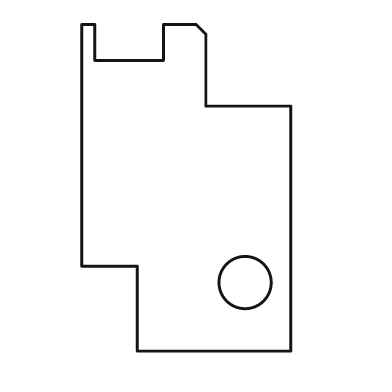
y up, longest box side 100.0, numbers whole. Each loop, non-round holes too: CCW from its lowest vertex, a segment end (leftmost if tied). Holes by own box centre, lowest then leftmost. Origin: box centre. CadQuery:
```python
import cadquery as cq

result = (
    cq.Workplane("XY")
    .moveTo(-15.0, -50.0)
    .lineTo(32.0, -50.0)
    .lineTo(32.0, 25.0)
    .lineTo(6.0, 25.0)
    .lineTo(6.0, 47.0)
    .lineTo(3.0, 50.0)
    .lineTo(-7.0, 50.0)
    .lineTo(-7.0, 39.0)
    .lineTo(-28.0, 39.0)
    .lineTo(-28.0, 50.0)
    .lineTo(-32.0, 50.0)
    .lineTo(-32.0, -24.0)
    .lineTo(-15.0, -24.0)
    .close()
    .moveTo(18.0, -29.0)
    .circle(8.0)
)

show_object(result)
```